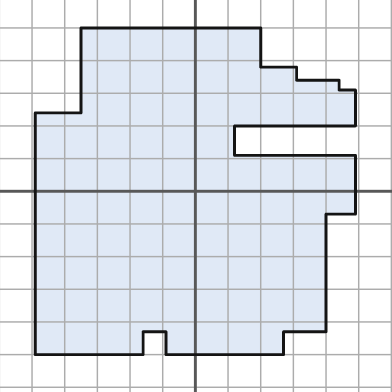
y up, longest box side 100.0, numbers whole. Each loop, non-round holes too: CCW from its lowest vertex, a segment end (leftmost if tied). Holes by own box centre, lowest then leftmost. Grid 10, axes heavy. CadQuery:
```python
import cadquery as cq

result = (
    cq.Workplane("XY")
    .moveTo(-49.0, -50.0)
    .lineTo(-16.0, -50.0)
    .lineTo(-16.0, -43.0)
    .lineTo(-9.0, -43.0)
    .lineTo(-9.0, -50.0)
    .lineTo(27.0, -50.0)
    .lineTo(27.0, -43.0)
    .lineTo(40.0, -43.0)
    .lineTo(40.0, -7.0)
    .lineTo(49.0, -7.0)
    .lineTo(49.0, 11.0)
    .lineTo(12.0, 11.0)
    .lineTo(12.0, 20.0)
    .lineTo(49.0, 20.0)
    .lineTo(49.0, 31.0)
    .lineTo(44.0, 31.0)
    .lineTo(44.0, 34.0)
    .lineTo(31.0, 34.0)
    .lineTo(31.0, 38.0)
    .lineTo(20.0, 38.0)
    .lineTo(20.0, 50.0)
    .lineTo(-35.0, 50.0)
    .lineTo(-35.0, 24.0)
    .lineTo(-49.0, 24.0)
    .close()
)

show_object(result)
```